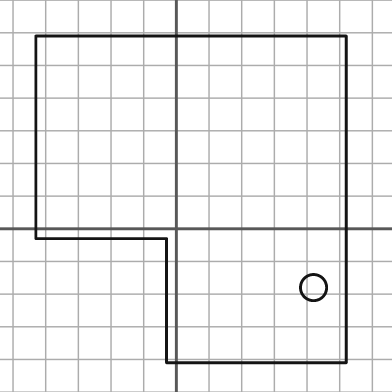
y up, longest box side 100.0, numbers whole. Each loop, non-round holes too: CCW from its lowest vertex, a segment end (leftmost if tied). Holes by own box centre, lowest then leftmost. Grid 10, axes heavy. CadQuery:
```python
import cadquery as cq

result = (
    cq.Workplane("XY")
    .moveTo(-3.0, -41.0)
    .lineTo(52.0, -41.0)
    .lineTo(52.0, 59.0)
    .lineTo(-43.0, 59.0)
    .lineTo(-43.0, -3.0)
    .lineTo(-3.0, -3.0)
    .close()
    .moveTo(42.0, -18.0)
    .circle(4.0)
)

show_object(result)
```